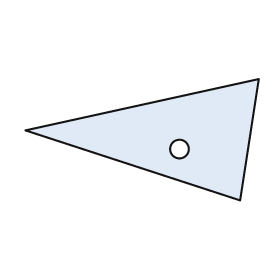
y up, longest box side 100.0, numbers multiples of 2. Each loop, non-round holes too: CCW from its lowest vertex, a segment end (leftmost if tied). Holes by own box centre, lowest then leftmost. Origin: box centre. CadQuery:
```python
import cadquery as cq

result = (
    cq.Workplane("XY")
    .moveTo(42.0, -26.0)
    .lineTo(50.0, 26.0)
    .lineTo(-50.0, 4.0)
    .close()
    .moveTo(16.0, -4.0)
    .circle(4.0)
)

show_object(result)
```